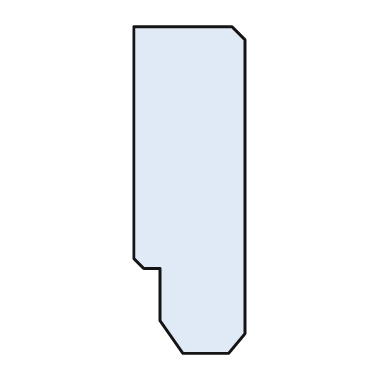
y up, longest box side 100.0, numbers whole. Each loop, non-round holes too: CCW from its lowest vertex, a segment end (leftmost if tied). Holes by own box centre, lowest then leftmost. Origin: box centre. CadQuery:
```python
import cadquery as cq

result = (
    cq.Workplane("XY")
    .moveTo(-2.0, -50.0)
    .lineTo(12.0, -50.0)
    .lineTo(17.0, -44.0)
    .lineTo(17.0, 46.0)
    .lineTo(13.0, 50.0)
    .lineTo(-17.0, 50.0)
    .lineTo(-17.0, -21.0)
    .lineTo(-14.0, -24.0)
    .lineTo(-9.0, -24.0)
    .lineTo(-9.0, -40.0)
    .close()
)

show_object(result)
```